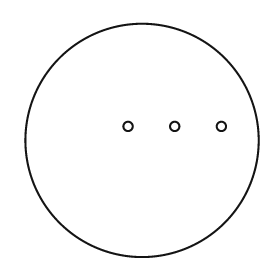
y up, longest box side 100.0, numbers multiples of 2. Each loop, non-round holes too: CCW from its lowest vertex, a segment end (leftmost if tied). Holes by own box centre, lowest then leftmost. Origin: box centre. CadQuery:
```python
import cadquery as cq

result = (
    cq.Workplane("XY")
    .moveTo(0.0, 0.0)
    .circle(50.0)
    .moveTo(-6.0, 6.0)
    .circle(2.0)
    .moveTo(14.0, 6.0)
    .circle(2.0)
    .moveTo(34.0, 6.0)
    .circle(2.0)
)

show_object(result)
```